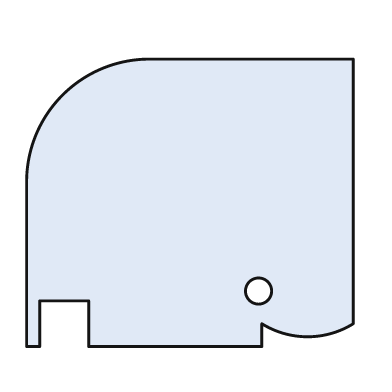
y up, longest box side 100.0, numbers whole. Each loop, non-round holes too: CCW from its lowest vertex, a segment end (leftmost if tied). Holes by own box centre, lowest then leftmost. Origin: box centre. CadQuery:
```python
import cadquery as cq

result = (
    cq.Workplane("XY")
    .moveTo(-50.0, -44.0)
    .lineTo(-46.0, -44.0)
    .lineTo(-46.0, -30.0)
    .lineTo(-31.0, -30.0)
    .lineTo(-31.0, -44.0)
    .lineTo(22.0, -44.0)
    .lineTo(22.0, -37.0)
    .threePointArc((36.0, -41.0), (50.0, -37.0))
    .lineTo(50.0, 44.0)
    .lineTo(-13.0, 44.0)
    .threePointArc((-39.0, 33.0), (-50.0, 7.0))
    .close()
    .moveTo(21.0, -27.0)
    .circle(4.0)
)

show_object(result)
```